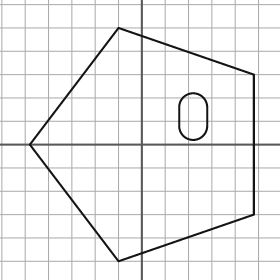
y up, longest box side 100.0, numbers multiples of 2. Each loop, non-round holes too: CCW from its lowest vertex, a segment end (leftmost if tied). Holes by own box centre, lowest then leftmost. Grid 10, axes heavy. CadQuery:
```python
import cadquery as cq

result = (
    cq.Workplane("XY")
    .moveTo(-10.0, -50.0)
    .lineTo(48.0, -30.0)
    .lineTo(48.0, 30.0)
    .lineTo(-10.0, 50.0)
    .lineTo(-48.0, 0.0)
    .close()
    .moveTo(16.0, 8.0)
    .threePointArc((22.0, 2.0), (28.0, 8.0))
    .lineTo(28.0, 16.0)
    .threePointArc((22.0, 22.0), (16.0, 16.0))
    .close()
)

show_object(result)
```